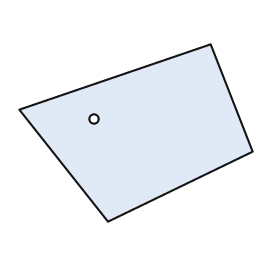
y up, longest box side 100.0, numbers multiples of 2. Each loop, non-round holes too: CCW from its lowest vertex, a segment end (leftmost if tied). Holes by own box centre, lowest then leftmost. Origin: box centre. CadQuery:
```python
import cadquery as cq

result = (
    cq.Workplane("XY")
    .moveTo(-12.0, -38.0)
    .lineTo(50.0, -8.0)
    .lineTo(32.0, 38.0)
    .lineTo(-50.0, 10.0)
    .close()
    .moveTo(-18.0, 6.0)
    .circle(2.0)
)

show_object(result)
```